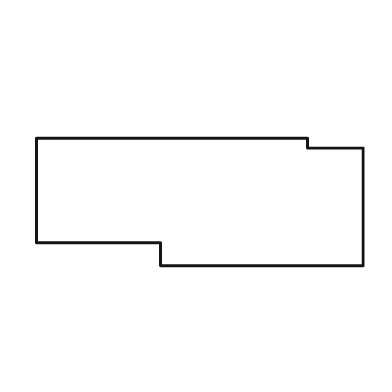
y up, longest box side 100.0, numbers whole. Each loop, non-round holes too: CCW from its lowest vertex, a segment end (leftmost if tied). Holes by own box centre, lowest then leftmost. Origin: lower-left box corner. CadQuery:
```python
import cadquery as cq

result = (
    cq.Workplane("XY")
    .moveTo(38.0, 0.0)
    .lineTo(100.0, 0.0)
    .lineTo(100.0, 36.0)
    .lineTo(83.0, 36.0)
    .lineTo(83.0, 39.0)
    .lineTo(0.0, 39.0)
    .lineTo(0.0, 7.0)
    .lineTo(38.0, 7.0)
    .close()
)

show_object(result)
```